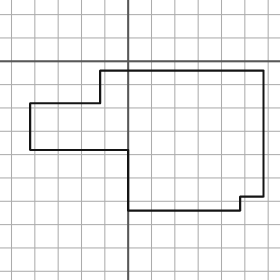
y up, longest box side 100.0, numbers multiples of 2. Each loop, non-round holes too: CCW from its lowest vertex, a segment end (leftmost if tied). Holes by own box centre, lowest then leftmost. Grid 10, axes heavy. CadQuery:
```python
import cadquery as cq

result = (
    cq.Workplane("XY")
    .moveTo(0.0, -64.0)
    .lineTo(48.0, -64.0)
    .lineTo(48.0, -58.0)
    .lineTo(58.0, -58.0)
    .lineTo(58.0, -4.0)
    .lineTo(-12.0, -4.0)
    .lineTo(-12.0, -18.0)
    .lineTo(-42.0, -18.0)
    .lineTo(-42.0, -38.0)
    .lineTo(0.0, -38.0)
    .close()
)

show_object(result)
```